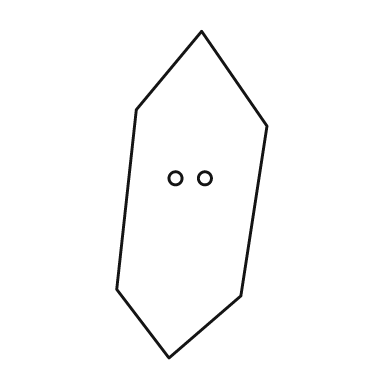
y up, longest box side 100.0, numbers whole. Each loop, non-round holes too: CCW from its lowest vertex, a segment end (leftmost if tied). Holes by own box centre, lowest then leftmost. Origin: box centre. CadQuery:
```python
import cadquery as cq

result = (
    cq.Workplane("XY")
    .moveTo(-7.0, -50.0)
    .lineTo(15.0, -31.0)
    .lineTo(23.0, 21.0)
    .lineTo(3.0, 50.0)
    .lineTo(-17.0, 26.0)
    .lineTo(-23.0, -29.0)
    .close()
    .moveTo(-5.0, 5.0)
    .circle(2.0)
    .moveTo(4.0, 5.0)
    .circle(2.0)
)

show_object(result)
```